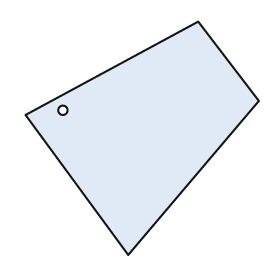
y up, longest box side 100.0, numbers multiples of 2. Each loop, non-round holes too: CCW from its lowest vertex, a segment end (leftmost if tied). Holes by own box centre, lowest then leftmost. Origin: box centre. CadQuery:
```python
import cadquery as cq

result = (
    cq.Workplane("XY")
    .moveTo(-6.0, -50.0)
    .lineTo(50.0, 16.0)
    .lineTo(24.0, 50.0)
    .lineTo(-50.0, 10.0)
    .close()
    .moveTo(-34.0, 12.0)
    .circle(2.0)
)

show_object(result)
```